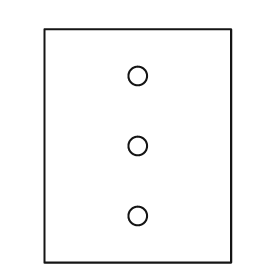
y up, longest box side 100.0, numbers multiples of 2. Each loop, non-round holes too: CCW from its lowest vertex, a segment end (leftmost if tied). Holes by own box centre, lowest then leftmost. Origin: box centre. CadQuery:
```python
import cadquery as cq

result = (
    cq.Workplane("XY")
    .moveTo(-40.0, -50.0)
    .lineTo(40.0, -50.0)
    .lineTo(40.0, 50.0)
    .lineTo(-40.0, 50.0)
    .close()
    .moveTo(0.0, -30.0)
    .circle(4.0)
    .moveTo(0.0, 0.0)
    .circle(4.0)
    .moveTo(0.0, 30.0)
    .circle(4.0)
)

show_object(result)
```